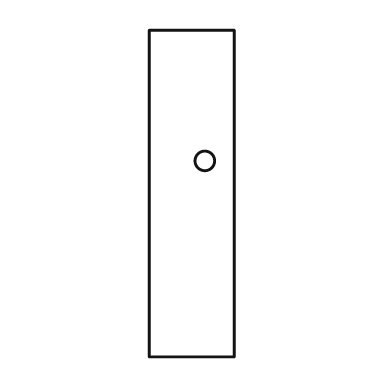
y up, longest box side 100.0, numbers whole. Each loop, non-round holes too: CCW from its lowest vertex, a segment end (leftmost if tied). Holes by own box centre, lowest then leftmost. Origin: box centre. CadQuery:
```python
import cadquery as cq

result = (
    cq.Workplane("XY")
    .moveTo(-13.0, -50.0)
    .lineTo(13.0, -50.0)
    .lineTo(13.0, 50.0)
    .lineTo(-13.0, 50.0)
    .close()
    .moveTo(4.0, 10.0)
    .circle(3.0)
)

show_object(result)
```